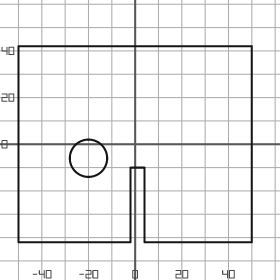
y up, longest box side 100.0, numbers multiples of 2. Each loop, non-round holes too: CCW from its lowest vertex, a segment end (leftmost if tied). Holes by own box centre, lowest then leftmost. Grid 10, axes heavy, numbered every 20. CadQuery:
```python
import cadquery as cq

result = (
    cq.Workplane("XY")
    .moveTo(-50.0, -42.0)
    .lineTo(-2.0, -42.0)
    .lineTo(-2.0, -10.0)
    .lineTo(4.0, -10.0)
    .lineTo(4.0, -42.0)
    .lineTo(50.0, -42.0)
    .lineTo(50.0, 42.0)
    .lineTo(-50.0, 42.0)
    .close()
    .moveTo(-20.0, -6.0)
    .circle(8.0)
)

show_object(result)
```